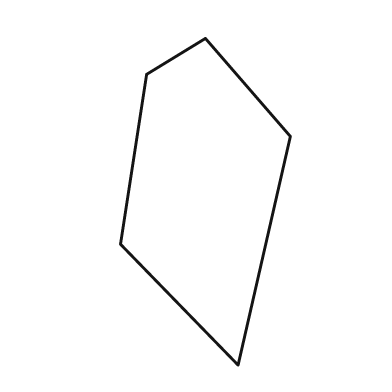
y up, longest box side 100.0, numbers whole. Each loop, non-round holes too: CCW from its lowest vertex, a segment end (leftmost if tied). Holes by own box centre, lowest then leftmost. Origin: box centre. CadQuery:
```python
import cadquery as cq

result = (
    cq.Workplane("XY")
    .moveTo(10.0, -50.0)
    .lineTo(26.0, 20.0)
    .lineTo(0.0, 50.0)
    .lineTo(-18.0, 39.0)
    .lineTo(-26.0, -13.0)
    .close()
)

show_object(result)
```